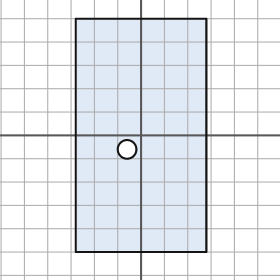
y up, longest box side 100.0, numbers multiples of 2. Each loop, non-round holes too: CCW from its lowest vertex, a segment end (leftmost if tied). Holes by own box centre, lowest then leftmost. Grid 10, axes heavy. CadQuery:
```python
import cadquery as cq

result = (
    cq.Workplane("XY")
    .moveTo(-28.0, -50.0)
    .lineTo(28.0, -50.0)
    .lineTo(28.0, 50.0)
    .lineTo(-28.0, 50.0)
    .close()
    .moveTo(-6.0, -6.0)
    .circle(4.0)
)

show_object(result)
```